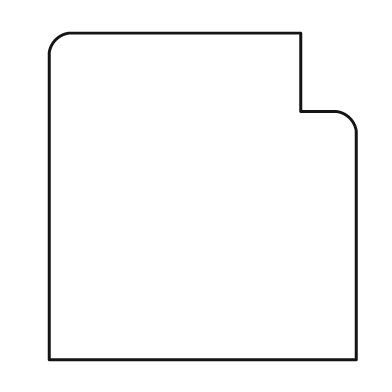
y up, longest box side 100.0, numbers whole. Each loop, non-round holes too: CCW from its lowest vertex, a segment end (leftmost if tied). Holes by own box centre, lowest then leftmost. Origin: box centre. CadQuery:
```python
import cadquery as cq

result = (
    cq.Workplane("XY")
    .moveTo(-47.0, -50.0)
    .lineTo(47.0, -50.0)
    .lineTo(47.0, 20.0)
    .threePointArc((45.0, 24.0), (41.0, 26.0))
    .lineTo(30.0, 26.0)
    .lineTo(30.0, 50.0)
    .lineTo(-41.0, 50.0)
    .threePointArc((-45.0, 48.0), (-47.0, 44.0))
    .close()
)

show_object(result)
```